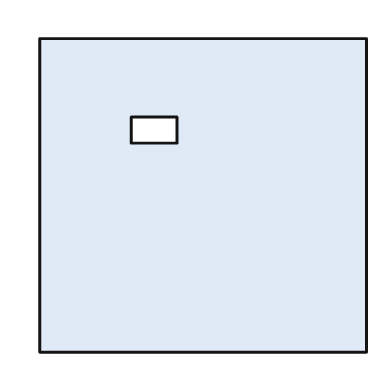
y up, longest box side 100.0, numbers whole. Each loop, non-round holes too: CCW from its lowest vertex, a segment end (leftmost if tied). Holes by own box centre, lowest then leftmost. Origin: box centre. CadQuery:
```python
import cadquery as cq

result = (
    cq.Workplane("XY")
    .moveTo(-50.0, -48.0)
    .lineTo(50.0, -48.0)
    .lineTo(50.0, 48.0)
    .lineTo(-50.0, 48.0)
    .close()
    .moveTo(-22.0, 16.0)
    .lineTo(-8.0, 16.0)
    .lineTo(-8.0, 24.0)
    .lineTo(-22.0, 24.0)
    .close()
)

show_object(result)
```